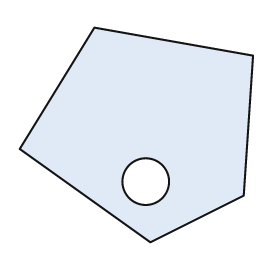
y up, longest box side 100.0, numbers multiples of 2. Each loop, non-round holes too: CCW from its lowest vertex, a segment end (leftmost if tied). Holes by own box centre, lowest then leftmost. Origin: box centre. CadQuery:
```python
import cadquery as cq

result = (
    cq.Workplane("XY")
    .moveTo(6.0, -46.0)
    .lineTo(46.0, -26.0)
    .lineTo(50.0, 34.0)
    .lineTo(-18.0, 46.0)
    .lineTo(-50.0, -6.0)
    .close()
    .moveTo(4.0, -20.0)
    .circle(10.0)
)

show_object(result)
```